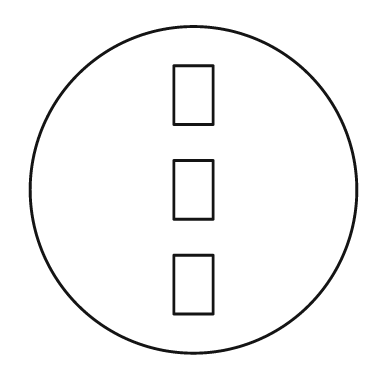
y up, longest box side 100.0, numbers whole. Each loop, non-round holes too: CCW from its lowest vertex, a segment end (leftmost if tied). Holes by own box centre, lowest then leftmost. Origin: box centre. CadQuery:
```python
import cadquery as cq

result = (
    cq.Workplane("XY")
    .moveTo(0.0, 0.0)
    .circle(50.0)
    .moveTo(-6.0, -38.0)
    .lineTo(6.0, -38.0)
    .lineTo(6.0, -20.0)
    .lineTo(-6.0, -20.0)
    .close()
    .moveTo(-6.0, -9.0)
    .lineTo(6.0, -9.0)
    .lineTo(6.0, 9.0)
    .lineTo(-6.0, 9.0)
    .close()
    .moveTo(-6.0, 20.0)
    .lineTo(6.0, 20.0)
    .lineTo(6.0, 38.0)
    .lineTo(-6.0, 38.0)
    .close()
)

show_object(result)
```